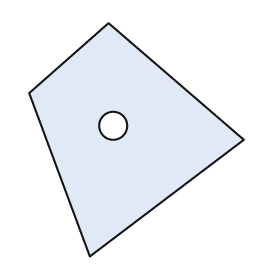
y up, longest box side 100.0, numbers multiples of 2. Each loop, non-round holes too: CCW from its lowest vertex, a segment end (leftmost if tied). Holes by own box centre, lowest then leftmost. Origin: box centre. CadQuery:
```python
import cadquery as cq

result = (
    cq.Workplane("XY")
    .moveTo(-20.0, -50.0)
    .lineTo(46.0, 0.0)
    .lineTo(-12.0, 50.0)
    .lineTo(-46.0, 20.0)
    .close()
    .moveTo(-10.0, 6.0)
    .circle(6.0)
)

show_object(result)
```